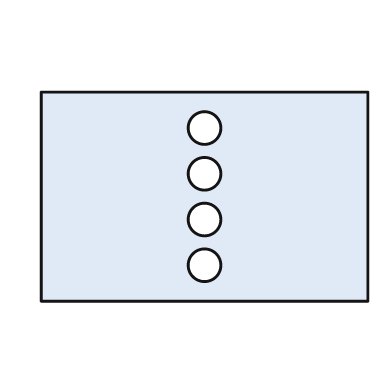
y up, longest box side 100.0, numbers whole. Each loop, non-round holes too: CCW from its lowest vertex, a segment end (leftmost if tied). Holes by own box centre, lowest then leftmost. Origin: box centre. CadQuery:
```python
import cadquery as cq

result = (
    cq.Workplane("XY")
    .moveTo(-50.0, -32.0)
    .lineTo(50.0, -32.0)
    .lineTo(50.0, 32.0)
    .lineTo(-50.0, 32.0)
    .close()
    .moveTo(0.0, -21.0)
    .circle(5.0)
    .moveTo(0.0, -7.0)
    .circle(5.0)
    .moveTo(0.0, 7.0)
    .circle(5.0)
    .moveTo(0.0, 21.0)
    .circle(5.0)
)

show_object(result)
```